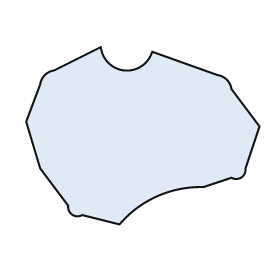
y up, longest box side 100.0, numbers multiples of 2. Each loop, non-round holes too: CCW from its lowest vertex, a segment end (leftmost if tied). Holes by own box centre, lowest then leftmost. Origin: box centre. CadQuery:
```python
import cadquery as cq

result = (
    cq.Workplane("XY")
    .moveTo(-10.0, -38.0)
    .threePointArc((6.0, -26.0), (26.0, -22.0))
    .lineTo(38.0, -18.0)
    .threePointArc((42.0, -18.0), (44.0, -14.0))
    .lineTo(50.0, 4.0)
    .lineTo(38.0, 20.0)
    .threePointArc((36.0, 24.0), (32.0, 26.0))
    .lineTo(4.0, 36.0)
    .threePointArc((-8.0, 28.0), (-18.0, 38.0))
    .lineTo(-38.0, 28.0)
    .threePointArc((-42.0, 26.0), (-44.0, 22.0))
    .lineTo(-50.0, 6.0)
    .lineTo(-44.0, -14.0)
    .lineTo(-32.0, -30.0)
    .threePointArc((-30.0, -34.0), (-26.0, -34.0))
    .close()
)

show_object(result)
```